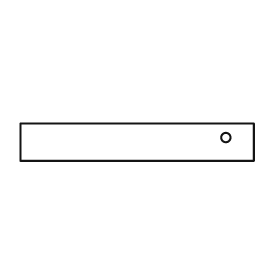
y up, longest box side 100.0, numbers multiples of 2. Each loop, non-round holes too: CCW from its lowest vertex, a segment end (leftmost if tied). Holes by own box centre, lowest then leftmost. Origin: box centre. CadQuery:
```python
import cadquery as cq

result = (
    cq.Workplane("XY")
    .moveTo(-50.0, -8.0)
    .lineTo(50.0, -8.0)
    .lineTo(50.0, 8.0)
    .lineTo(-50.0, 8.0)
    .close()
    .moveTo(38.0, 2.0)
    .circle(2.0)
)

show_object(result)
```